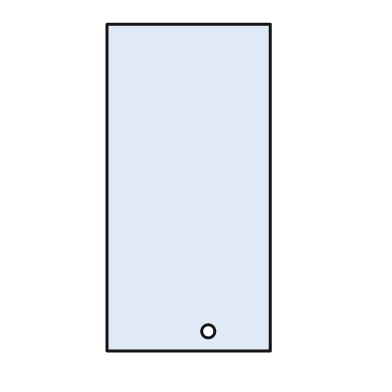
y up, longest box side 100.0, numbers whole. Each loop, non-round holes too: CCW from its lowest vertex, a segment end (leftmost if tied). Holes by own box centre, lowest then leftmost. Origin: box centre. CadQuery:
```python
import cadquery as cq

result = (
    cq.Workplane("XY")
    .moveTo(-25.0, -50.0)
    .lineTo(25.0, -50.0)
    .lineTo(25.0, 50.0)
    .lineTo(-25.0, 50.0)
    .close()
    .moveTo(6.0, -44.0)
    .circle(2.0)
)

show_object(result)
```